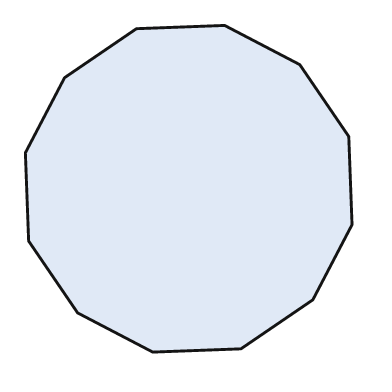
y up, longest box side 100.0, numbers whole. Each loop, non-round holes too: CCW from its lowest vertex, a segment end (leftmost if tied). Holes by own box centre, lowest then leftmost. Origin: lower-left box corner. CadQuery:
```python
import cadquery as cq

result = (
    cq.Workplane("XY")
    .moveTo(39.0, 0.0)
    .lineTo(66.0, 1.0)
    .lineTo(88.0, 16.0)
    .lineTo(100.0, 39.0)
    .lineTo(99.0, 66.0)
    .lineTo(84.0, 88.0)
    .lineTo(61.0, 100.0)
    .lineTo(34.0, 99.0)
    .lineTo(12.0, 84.0)
    .lineTo(0.0, 61.0)
    .lineTo(1.0, 34.0)
    .lineTo(16.0, 12.0)
    .close()
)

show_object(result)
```